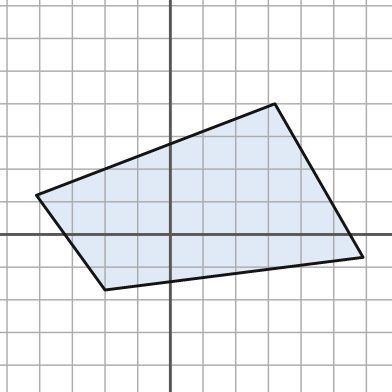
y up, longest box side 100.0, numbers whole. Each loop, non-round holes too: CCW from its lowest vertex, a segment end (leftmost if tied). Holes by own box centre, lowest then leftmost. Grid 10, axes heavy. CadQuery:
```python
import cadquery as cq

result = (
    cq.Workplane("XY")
    .moveTo(-20.0, -17.0)
    .lineTo(59.0, -7.0)
    .lineTo(32.0, 40.0)
    .lineTo(-41.0, 12.0)
    .close()
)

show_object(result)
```